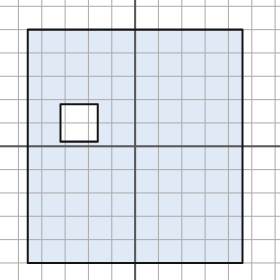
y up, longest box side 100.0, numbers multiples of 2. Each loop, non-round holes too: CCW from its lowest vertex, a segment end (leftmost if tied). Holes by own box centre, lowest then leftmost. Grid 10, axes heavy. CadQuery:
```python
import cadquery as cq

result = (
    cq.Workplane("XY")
    .moveTo(-46.0, -50.0)
    .lineTo(46.0, -50.0)
    .lineTo(46.0, 50.0)
    .lineTo(-46.0, 50.0)
    .close()
    .moveTo(-32.0, 2.0)
    .lineTo(-16.0, 2.0)
    .lineTo(-16.0, 18.0)
    .lineTo(-32.0, 18.0)
    .close()
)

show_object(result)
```